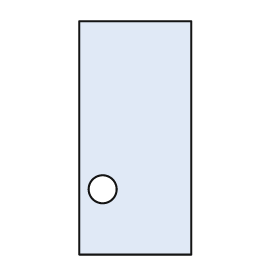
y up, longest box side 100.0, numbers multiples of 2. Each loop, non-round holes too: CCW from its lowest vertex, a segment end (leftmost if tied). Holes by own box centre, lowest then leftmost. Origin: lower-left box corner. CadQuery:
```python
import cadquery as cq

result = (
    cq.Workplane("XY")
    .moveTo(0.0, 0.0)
    .lineTo(48.0, 0.0)
    .lineTo(48.0, 100.0)
    .lineTo(0.0, 100.0)
    .close()
    .moveTo(10.0, 28.0)
    .circle(6.0)
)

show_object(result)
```